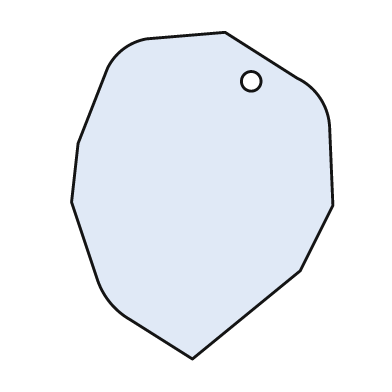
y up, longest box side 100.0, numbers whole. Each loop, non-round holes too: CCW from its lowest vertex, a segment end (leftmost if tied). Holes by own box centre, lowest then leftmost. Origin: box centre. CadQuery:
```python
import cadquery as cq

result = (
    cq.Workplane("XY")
    .moveTo(-3.0, -50.0)
    .lineTo(30.0, -23.0)
    .lineTo(40.0, -3.0)
    .lineTo(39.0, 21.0)
    .threePointArc((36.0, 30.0), (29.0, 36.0))
    .lineTo(7.0, 50.0)
    .lineTo(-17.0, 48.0)
    .threePointArc((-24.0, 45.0), (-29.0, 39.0))
    .lineTo(-38.0, 16.0)
    .lineTo(-40.0, -2.0)
    .lineTo(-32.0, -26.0)
    .threePointArc((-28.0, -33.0), (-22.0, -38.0))
    .close()
    .moveTo(15.0, 35.0)
    .circle(3.0)
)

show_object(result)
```